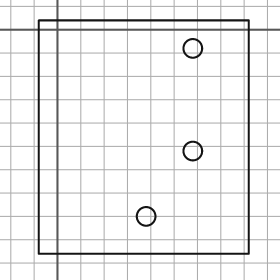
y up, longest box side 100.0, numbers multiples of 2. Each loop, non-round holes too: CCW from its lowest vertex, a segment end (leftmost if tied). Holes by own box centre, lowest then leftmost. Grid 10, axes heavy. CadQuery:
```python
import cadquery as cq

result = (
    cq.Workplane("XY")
    .moveTo(-8.0, -96.0)
    .lineTo(82.0, -96.0)
    .lineTo(82.0, 4.0)
    .lineTo(-8.0, 4.0)
    .close()
    .moveTo(38.0, -80.0)
    .circle(4.0)
    .moveTo(58.0, -52.0)
    .circle(4.0)
    .moveTo(58.0, -8.0)
    .circle(4.0)
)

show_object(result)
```